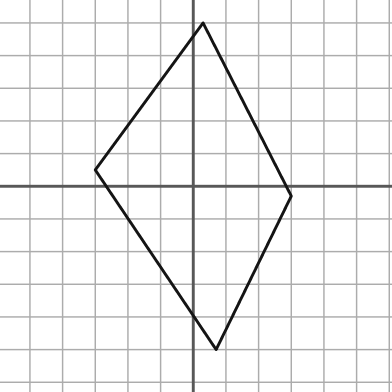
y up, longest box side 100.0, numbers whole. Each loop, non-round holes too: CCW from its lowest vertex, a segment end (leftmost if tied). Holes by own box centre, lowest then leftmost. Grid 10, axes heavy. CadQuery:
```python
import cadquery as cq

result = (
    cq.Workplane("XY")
    .moveTo(7.0, -50.0)
    .lineTo(30.0, -3.0)
    .lineTo(3.0, 50.0)
    .lineTo(-30.0, 5.0)
    .close()
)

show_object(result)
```